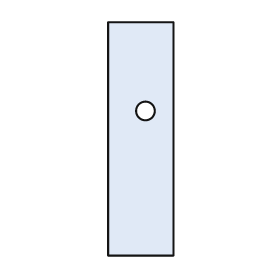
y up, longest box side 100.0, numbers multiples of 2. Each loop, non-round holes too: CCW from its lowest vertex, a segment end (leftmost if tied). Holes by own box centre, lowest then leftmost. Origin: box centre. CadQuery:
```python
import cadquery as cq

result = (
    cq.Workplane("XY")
    .moveTo(-14.0, -50.0)
    .lineTo(14.0, -50.0)
    .lineTo(14.0, 50.0)
    .lineTo(-14.0, 50.0)
    .close()
    .moveTo(2.0, 12.0)
    .circle(4.0)
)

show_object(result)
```